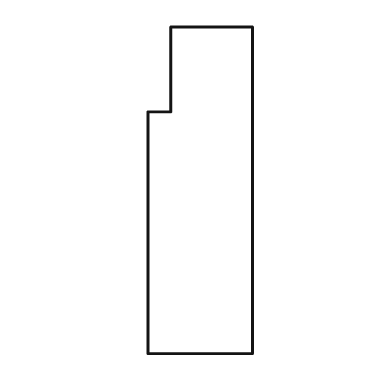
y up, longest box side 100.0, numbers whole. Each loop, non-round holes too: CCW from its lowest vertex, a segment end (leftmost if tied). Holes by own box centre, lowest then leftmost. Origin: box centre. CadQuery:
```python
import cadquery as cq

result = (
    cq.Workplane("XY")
    .moveTo(-16.0, -50.0)
    .lineTo(16.0, -50.0)
    .lineTo(16.0, 50.0)
    .lineTo(-9.0, 50.0)
    .lineTo(-9.0, 24.0)
    .lineTo(-16.0, 24.0)
    .close()
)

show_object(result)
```